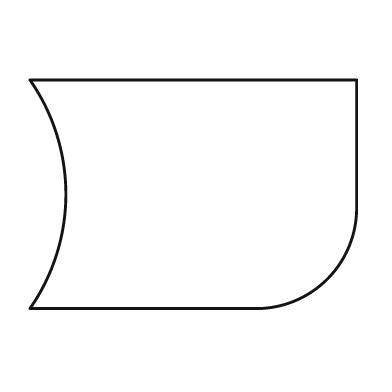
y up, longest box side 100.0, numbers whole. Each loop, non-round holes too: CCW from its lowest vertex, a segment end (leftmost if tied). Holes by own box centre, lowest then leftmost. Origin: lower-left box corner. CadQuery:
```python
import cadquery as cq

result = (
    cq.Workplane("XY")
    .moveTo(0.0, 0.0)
    .lineTo(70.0, 0.0)
    .threePointArc((91.0, 9.0), (100.0, 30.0))
    .lineTo(100.0, 70.0)
    .lineTo(0.0, 70.0)
    .threePointArc((11.0, 35.0), (0.0, 0.0))
    .close()
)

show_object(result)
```